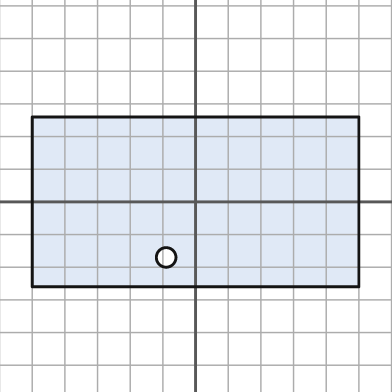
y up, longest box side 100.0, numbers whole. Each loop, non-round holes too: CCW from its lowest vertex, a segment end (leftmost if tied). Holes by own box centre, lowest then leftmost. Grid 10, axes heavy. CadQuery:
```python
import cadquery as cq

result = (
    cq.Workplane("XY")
    .moveTo(-50.0, -26.0)
    .lineTo(50.0, -26.0)
    .lineTo(50.0, 26.0)
    .lineTo(-50.0, 26.0)
    .close()
    .moveTo(-9.0, -17.0)
    .circle(3.0)
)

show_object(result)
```